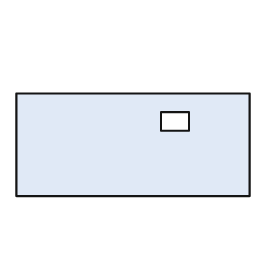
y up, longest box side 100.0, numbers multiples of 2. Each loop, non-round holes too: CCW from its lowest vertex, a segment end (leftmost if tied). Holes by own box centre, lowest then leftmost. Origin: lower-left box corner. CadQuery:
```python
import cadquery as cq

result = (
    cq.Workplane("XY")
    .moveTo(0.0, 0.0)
    .lineTo(100.0, 0.0)
    .lineTo(100.0, 44.0)
    .lineTo(0.0, 44.0)
    .close()
    .moveTo(62.0, 28.0)
    .lineTo(74.0, 28.0)
    .lineTo(74.0, 36.0)
    .lineTo(62.0, 36.0)
    .close()
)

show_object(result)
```